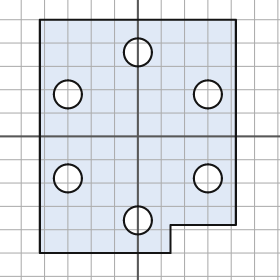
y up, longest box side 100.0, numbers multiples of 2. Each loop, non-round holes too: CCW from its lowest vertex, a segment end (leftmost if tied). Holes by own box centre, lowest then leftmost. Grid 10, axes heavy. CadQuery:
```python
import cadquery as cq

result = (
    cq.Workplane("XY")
    .moveTo(-42.0, -50.0)
    .lineTo(14.0, -50.0)
    .lineTo(14.0, -38.0)
    .lineTo(42.0, -38.0)
    .lineTo(42.0, 50.0)
    .lineTo(-42.0, 50.0)
    .close()
    .moveTo(0.0, -36.0)
    .circle(6.0)
    .moveTo(-30.0, -18.0)
    .circle(6.0)
    .moveTo(30.0, -18.0)
    .circle(6.0)
    .moveTo(-30.0, 18.0)
    .circle(6.0)
    .moveTo(30.0, 18.0)
    .circle(6.0)
    .moveTo(0.0, 36.0)
    .circle(6.0)
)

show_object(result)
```